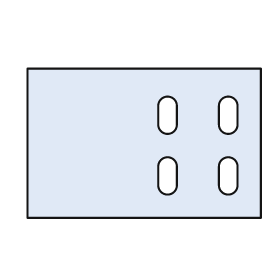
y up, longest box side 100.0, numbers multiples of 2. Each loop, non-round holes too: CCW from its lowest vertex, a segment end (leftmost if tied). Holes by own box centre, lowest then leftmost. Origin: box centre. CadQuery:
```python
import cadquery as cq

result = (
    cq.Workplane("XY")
    .moveTo(-50.0, -32.0)
    .lineTo(50.0, -32.0)
    .lineTo(50.0, 32.0)
    .lineTo(-50.0, 32.0)
    .close()
    .moveTo(6.0, -18.0)
    .threePointArc((10.0, -22.0), (14.0, -18.0))
    .lineTo(14.0, -10.0)
    .threePointArc((10.0, -6.0), (6.0, -10.0))
    .close()
    .moveTo(32.0, -18.0)
    .threePointArc((36.0, -22.0), (40.0, -18.0))
    .lineTo(40.0, -10.0)
    .threePointArc((36.0, -6.0), (32.0, -10.0))
    .close()
    .moveTo(6.0, 8.0)
    .threePointArc((10.0, 4.0), (14.0, 8.0))
    .lineTo(14.0, 16.0)
    .threePointArc((10.0, 20.0), (6.0, 16.0))
    .close()
    .moveTo(32.0, 8.0)
    .threePointArc((36.0, 4.0), (40.0, 8.0))
    .lineTo(40.0, 16.0)
    .threePointArc((36.0, 20.0), (32.0, 16.0))
    .close()
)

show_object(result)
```